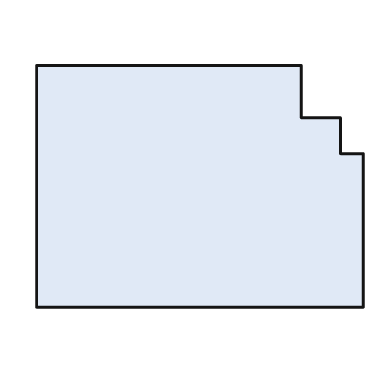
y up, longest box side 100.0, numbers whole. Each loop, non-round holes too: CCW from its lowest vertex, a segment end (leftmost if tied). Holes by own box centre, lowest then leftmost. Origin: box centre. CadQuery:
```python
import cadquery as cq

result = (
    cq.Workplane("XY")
    .moveTo(-50.0, -37.0)
    .lineTo(50.0, -37.0)
    .lineTo(50.0, 10.0)
    .lineTo(43.0, 10.0)
    .lineTo(43.0, 21.0)
    .lineTo(31.0, 21.0)
    .lineTo(31.0, 37.0)
    .lineTo(-50.0, 37.0)
    .close()
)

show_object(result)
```